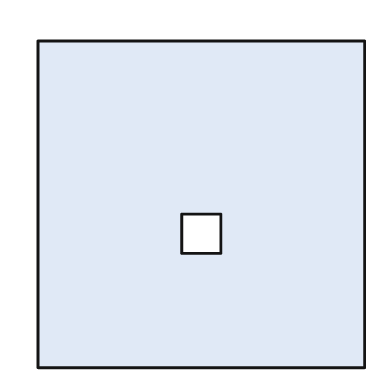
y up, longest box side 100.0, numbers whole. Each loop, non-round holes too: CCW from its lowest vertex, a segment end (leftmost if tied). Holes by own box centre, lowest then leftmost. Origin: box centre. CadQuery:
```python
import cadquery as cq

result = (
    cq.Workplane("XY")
    .moveTo(-50.0, -50.0)
    .lineTo(50.0, -50.0)
    .lineTo(50.0, 50.0)
    .lineTo(-50.0, 50.0)
    .close()
    .moveTo(-6.0, -15.0)
    .lineTo(6.0, -15.0)
    .lineTo(6.0, -3.0)
    .lineTo(-6.0, -3.0)
    .close()
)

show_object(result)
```